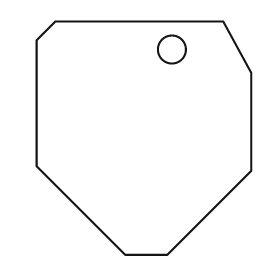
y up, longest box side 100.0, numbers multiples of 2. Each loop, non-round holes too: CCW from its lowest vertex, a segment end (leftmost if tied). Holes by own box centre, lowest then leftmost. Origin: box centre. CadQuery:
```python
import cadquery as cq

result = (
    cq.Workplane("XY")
    .moveTo(-8.0, -50.0)
    .lineTo(10.0, -50.0)
    .lineTo(46.0, -14.0)
    .lineTo(46.0, 28.0)
    .lineTo(34.0, 50.0)
    .lineTo(-38.0, 50.0)
    .lineTo(-46.0, 42.0)
    .lineTo(-46.0, -12.0)
    .close()
    .moveTo(12.0, 38.0)
    .circle(6.0)
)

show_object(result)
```